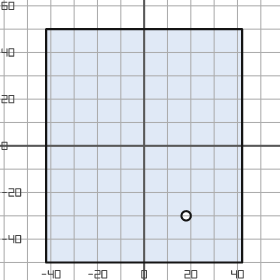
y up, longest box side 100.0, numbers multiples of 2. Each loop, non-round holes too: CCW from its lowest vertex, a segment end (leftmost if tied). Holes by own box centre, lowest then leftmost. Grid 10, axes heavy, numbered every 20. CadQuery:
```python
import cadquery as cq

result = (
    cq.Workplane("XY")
    .moveTo(-42.0, -50.0)
    .lineTo(42.0, -50.0)
    .lineTo(42.0, 50.0)
    .lineTo(-42.0, 50.0)
    .close()
    .moveTo(18.0, -30.0)
    .circle(2.0)
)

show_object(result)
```